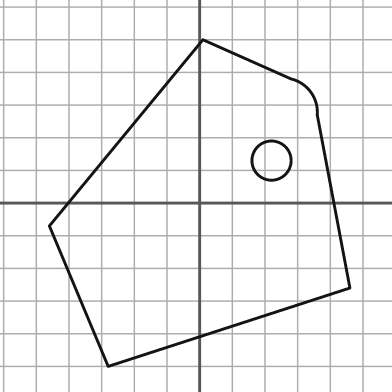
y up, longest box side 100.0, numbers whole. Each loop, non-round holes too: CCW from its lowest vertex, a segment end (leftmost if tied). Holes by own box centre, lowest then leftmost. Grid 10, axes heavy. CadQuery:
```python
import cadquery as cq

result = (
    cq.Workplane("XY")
    .moveTo(-28.0, -50.0)
    .lineTo(46.0, -26.0)
    .lineTo(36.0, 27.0)
    .threePointArc((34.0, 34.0), (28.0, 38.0))
    .lineTo(1.0, 50.0)
    .lineTo(-46.0, -7.0)
    .close()
    .moveTo(22.0, 13.0)
    .circle(6.0)
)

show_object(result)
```